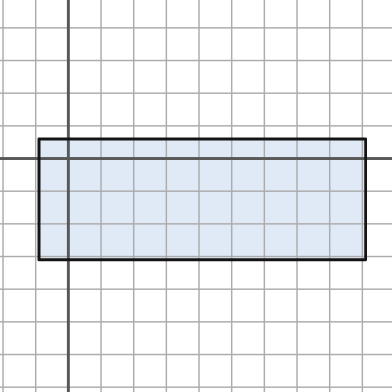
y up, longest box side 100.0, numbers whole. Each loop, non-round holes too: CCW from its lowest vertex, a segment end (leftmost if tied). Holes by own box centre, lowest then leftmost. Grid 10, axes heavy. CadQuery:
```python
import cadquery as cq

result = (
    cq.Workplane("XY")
    .moveTo(-9.0, -31.0)
    .lineTo(91.0, -31.0)
    .lineTo(91.0, 6.0)
    .lineTo(-9.0, 6.0)
    .close()
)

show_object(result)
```